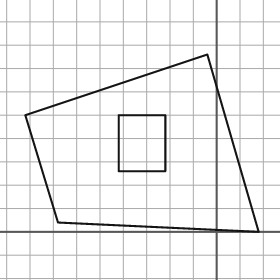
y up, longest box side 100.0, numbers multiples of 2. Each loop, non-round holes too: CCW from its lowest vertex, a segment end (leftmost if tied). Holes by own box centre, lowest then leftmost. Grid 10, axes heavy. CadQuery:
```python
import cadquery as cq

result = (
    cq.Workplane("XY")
    .moveTo(18.0, 0.0)
    .lineTo(-4.0, 76.0)
    .lineTo(-82.0, 50.0)
    .lineTo(-68.0, 4.0)
    .close()
    .moveTo(-42.0, 26.0)
    .lineTo(-22.0, 26.0)
    .lineTo(-22.0, 50.0)
    .lineTo(-42.0, 50.0)
    .close()
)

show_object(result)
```